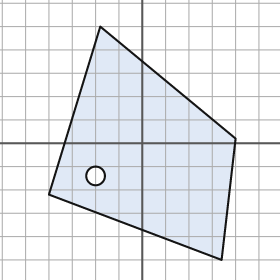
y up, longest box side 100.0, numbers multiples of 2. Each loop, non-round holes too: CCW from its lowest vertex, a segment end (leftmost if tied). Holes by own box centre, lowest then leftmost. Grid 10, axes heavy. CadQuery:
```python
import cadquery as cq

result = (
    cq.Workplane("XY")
    .moveTo(34.0, -50.0)
    .lineTo(40.0, 2.0)
    .lineTo(-18.0, 50.0)
    .lineTo(-40.0, -22.0)
    .close()
    .moveTo(-20.0, -14.0)
    .circle(4.0)
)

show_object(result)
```